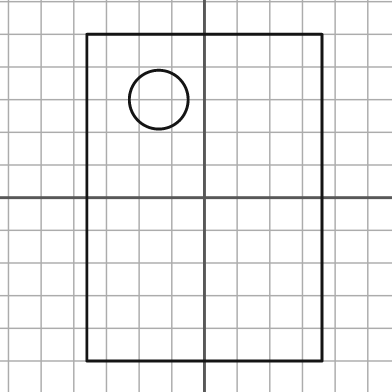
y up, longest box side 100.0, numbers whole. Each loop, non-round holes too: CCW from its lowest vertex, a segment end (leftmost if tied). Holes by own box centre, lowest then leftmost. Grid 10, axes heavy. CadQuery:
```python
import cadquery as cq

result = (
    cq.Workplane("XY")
    .moveTo(-36.0, -50.0)
    .lineTo(36.0, -50.0)
    .lineTo(36.0, 50.0)
    .lineTo(-36.0, 50.0)
    .close()
    .moveTo(-14.0, 30.0)
    .circle(9.0)
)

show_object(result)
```